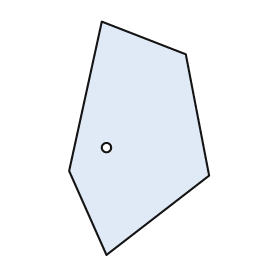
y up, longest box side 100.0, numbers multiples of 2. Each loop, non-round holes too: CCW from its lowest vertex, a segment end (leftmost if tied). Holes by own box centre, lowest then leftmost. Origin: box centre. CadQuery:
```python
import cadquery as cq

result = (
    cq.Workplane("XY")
    .moveTo(-14.0, -50.0)
    .lineTo(30.0, -16.0)
    .lineTo(20.0, 36.0)
    .lineTo(-16.0, 50.0)
    .lineTo(-30.0, -14.0)
    .close()
    .moveTo(-14.0, -4.0)
    .circle(2.0)
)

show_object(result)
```